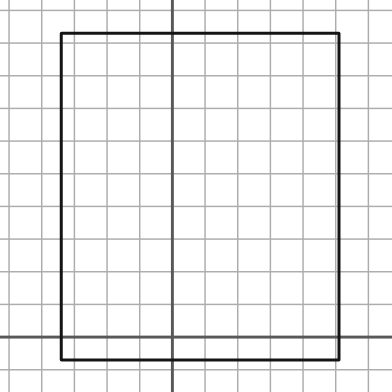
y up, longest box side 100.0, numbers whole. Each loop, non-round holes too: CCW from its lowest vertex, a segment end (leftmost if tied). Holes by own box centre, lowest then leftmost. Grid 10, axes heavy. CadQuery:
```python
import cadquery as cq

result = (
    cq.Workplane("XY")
    .moveTo(-34.0, -7.0)
    .lineTo(51.0, -7.0)
    .lineTo(51.0, 93.0)
    .lineTo(-34.0, 93.0)
    .close()
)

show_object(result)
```